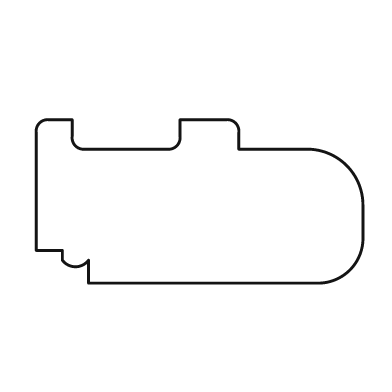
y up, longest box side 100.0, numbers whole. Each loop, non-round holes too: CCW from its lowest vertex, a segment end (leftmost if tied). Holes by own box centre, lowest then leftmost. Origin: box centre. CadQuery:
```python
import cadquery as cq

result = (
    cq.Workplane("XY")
    .moveTo(-34.0, -25.0)
    .lineTo(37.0, -25.0)
    .threePointArc((46.0, -21.0), (50.0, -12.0))
    .lineTo(50.0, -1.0)
    .threePointArc((45.0, 11.0), (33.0, 16.0))
    .lineTo(12.0, 16.0)
    .lineTo(12.0, 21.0)
    .threePointArc((11.0, 24.0), (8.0, 25.0))
    .lineTo(-6.0, 25.0)
    .lineTo(-6.0, 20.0)
    .threePointArc((-7.0, 17.0), (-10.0, 16.0))
    .lineTo(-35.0, 16.0)
    .threePointArc((-38.0, 17.0), (-39.0, 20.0))
    .lineTo(-39.0, 25.0)
    .lineTo(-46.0, 25.0)
    .threePointArc((-49.0, 24.0), (-50.0, 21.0))
    .lineTo(-50.0, -15.0)
    .lineTo(-42.0, -15.0)
    .lineTo(-42.0, -18.0)
    .threePointArc((-38.0, -20.0), (-34.0, -18.0))
    .close()
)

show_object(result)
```